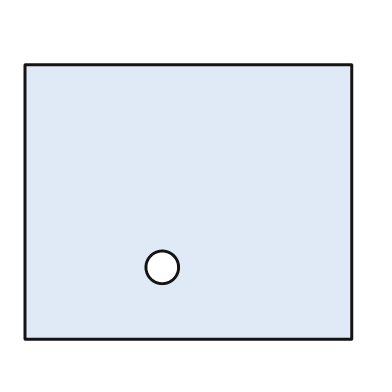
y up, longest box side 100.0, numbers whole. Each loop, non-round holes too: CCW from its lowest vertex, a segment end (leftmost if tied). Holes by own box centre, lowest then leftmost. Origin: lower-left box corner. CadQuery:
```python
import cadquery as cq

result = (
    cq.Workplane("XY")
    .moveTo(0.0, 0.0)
    .lineTo(100.0, 0.0)
    .lineTo(100.0, 84.0)
    .lineTo(0.0, 84.0)
    .close()
    .moveTo(42.0, 22.0)
    .circle(5.0)
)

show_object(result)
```